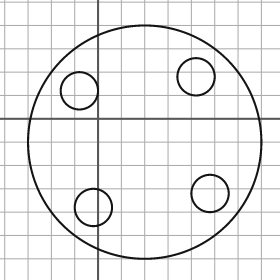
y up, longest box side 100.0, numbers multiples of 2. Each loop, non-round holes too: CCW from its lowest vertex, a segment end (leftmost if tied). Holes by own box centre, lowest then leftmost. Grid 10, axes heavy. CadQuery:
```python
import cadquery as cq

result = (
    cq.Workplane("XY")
    .moveTo(20.0, -10.0)
    .circle(50.0)
    .moveTo(-2.0, -38.0)
    .circle(8.0)
    .moveTo(48.0, -32.0)
    .circle(8.0)
    .moveTo(-8.0, 12.0)
    .circle(8.0)
    .moveTo(42.0, 18.0)
    .circle(8.0)
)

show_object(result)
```